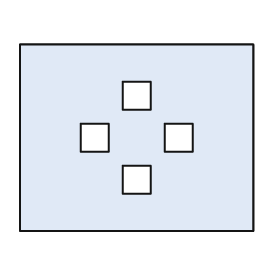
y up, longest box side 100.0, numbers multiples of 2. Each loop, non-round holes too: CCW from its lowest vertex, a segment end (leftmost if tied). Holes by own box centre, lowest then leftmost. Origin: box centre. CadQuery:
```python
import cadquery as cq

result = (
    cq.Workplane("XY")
    .moveTo(-50.0, -40.0)
    .lineTo(50.0, -40.0)
    .lineTo(50.0, 40.0)
    .lineTo(-50.0, 40.0)
    .close()
    .moveTo(-6.0, -24.0)
    .lineTo(6.0, -24.0)
    .lineTo(6.0, -12.0)
    .lineTo(-6.0, -12.0)
    .close()
    .moveTo(-24.0, -6.0)
    .lineTo(-12.0, -6.0)
    .lineTo(-12.0, 6.0)
    .lineTo(-24.0, 6.0)
    .close()
    .moveTo(12.0, -6.0)
    .lineTo(24.0, -6.0)
    .lineTo(24.0, 6.0)
    .lineTo(12.0, 6.0)
    .close()
    .moveTo(-6.0, 12.0)
    .lineTo(6.0, 12.0)
    .lineTo(6.0, 24.0)
    .lineTo(-6.0, 24.0)
    .close()
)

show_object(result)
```